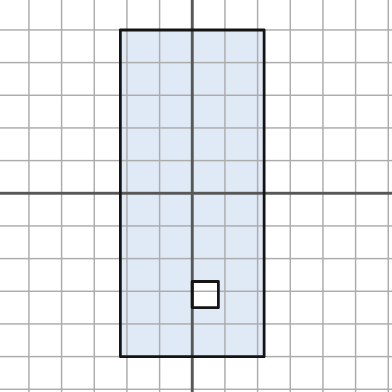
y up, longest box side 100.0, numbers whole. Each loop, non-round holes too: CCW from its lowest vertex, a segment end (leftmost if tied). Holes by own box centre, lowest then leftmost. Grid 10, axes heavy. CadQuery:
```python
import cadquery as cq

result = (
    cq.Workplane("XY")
    .moveTo(-22.0, -50.0)
    .lineTo(22.0, -50.0)
    .lineTo(22.0, 50.0)
    .lineTo(-22.0, 50.0)
    .close()
    .moveTo(0.0, -35.0)
    .lineTo(8.0, -35.0)
    .lineTo(8.0, -27.0)
    .lineTo(0.0, -27.0)
    .close()
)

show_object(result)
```